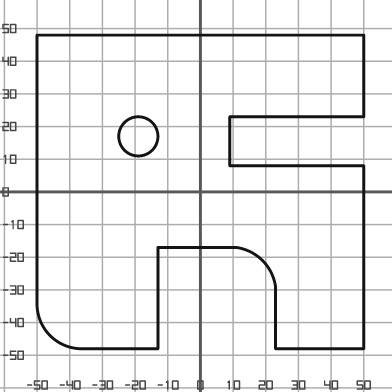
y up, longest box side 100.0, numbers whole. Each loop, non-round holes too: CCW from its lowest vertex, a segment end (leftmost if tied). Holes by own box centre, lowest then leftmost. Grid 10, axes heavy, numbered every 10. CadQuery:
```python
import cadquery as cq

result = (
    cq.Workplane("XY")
    .moveTo(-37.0, -48.0)
    .lineTo(-13.0, -48.0)
    .lineTo(-13.0, -17.0)
    .lineTo(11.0, -17.0)
    .threePointArc((19.0, -21.0), (23.0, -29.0))
    .lineTo(23.0, -48.0)
    .lineTo(50.0, -48.0)
    .lineTo(50.0, 8.0)
    .lineTo(9.0, 8.0)
    .lineTo(9.0, 23.0)
    .lineTo(50.0, 23.0)
    .lineTo(50.0, 48.0)
    .lineTo(-50.0, 48.0)
    .lineTo(-50.0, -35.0)
    .threePointArc((-46.0, -44.0), (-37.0, -48.0))
    .close()
    .moveTo(-19.0, 17.0)
    .circle(6.0)
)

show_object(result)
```